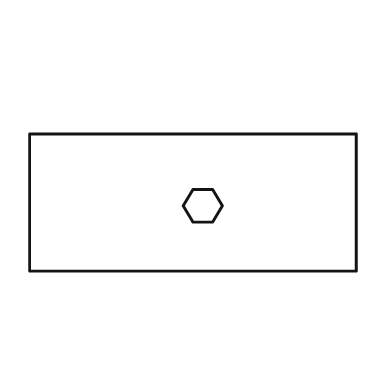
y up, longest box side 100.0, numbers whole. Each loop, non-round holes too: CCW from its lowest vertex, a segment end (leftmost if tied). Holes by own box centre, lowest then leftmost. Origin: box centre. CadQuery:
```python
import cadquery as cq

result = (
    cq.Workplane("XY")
    .moveTo(-50.0, -21.0)
    .lineTo(50.0, -21.0)
    .lineTo(50.0, 21.0)
    .lineTo(-50.0, 21.0)
    .close()
    .moveTo(0.0, -6.0)
    .lineTo(6.0, -6.0)
    .lineTo(9.0, -1.0)
    .lineTo(6.0, 4.0)
    .lineTo(0.0, 4.0)
    .lineTo(-3.0, -1.0)
    .close()
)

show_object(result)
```